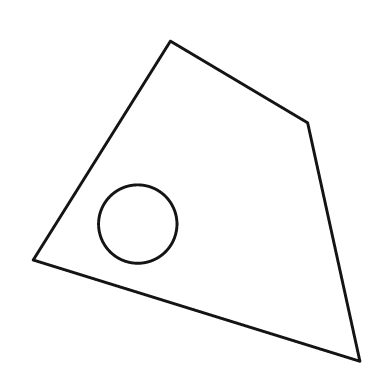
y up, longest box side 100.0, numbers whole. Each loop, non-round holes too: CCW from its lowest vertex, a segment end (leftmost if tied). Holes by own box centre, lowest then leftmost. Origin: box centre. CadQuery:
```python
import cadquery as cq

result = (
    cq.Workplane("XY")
    .moveTo(50.0, -49.0)
    .lineTo(34.0, 24.0)
    .lineTo(-8.0, 49.0)
    .lineTo(-50.0, -18.0)
    .close()
    .moveTo(-18.0, -7.0)
    .circle(12.0)
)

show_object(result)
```